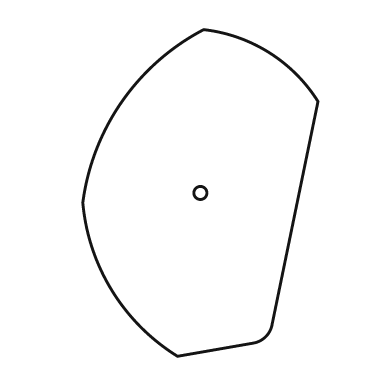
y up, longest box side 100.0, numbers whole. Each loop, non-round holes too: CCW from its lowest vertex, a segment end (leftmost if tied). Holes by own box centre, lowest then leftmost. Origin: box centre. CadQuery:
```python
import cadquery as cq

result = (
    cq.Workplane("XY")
    .moveTo(-7.0, -50.0)
    .lineTo(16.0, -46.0)
    .threePointArc((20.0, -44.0), (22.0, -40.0))
    .lineTo(36.0, 28.0)
    .threePointArc((21.0, 43.0), (1.0, 50.0))
    .threePointArc((-24.0, 28.0), (-36.0, -3.0))
    .threePointArc((-27.0, -30.0), (-7.0, -50.0))
    .close()
    .moveTo(0.0, 0.0)
    .circle(2.0)
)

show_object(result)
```